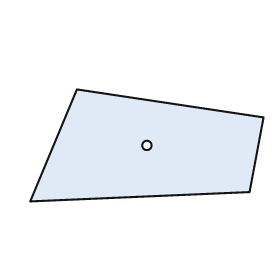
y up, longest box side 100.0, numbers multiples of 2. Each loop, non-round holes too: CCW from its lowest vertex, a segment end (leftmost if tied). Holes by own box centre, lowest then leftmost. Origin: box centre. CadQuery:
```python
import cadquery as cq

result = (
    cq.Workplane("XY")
    .moveTo(-50.0, -24.0)
    .lineTo(44.0, -20.0)
    .lineTo(50.0, 12.0)
    .lineTo(-30.0, 24.0)
    .close()
    .moveTo(0.0, 0.0)
    .circle(2.0)
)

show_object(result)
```